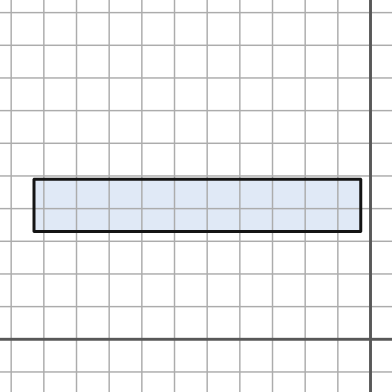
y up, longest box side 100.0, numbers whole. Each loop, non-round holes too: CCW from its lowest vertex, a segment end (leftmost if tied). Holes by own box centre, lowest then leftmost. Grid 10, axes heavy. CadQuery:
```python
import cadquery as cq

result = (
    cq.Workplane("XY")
    .moveTo(-103.0, 33.0)
    .lineTo(-3.0, 33.0)
    .lineTo(-3.0, 49.0)
    .lineTo(-103.0, 49.0)
    .close()
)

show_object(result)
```